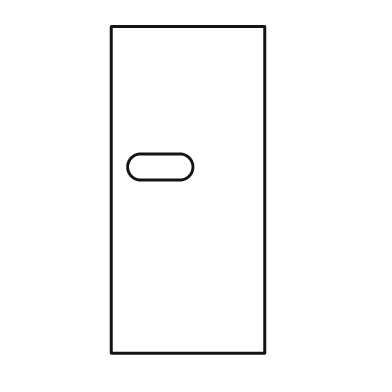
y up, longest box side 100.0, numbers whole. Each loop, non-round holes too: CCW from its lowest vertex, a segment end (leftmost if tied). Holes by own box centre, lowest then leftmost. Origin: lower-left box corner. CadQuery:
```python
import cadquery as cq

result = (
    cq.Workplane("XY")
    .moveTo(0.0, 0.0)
    .lineTo(47.0, 0.0)
    .lineTo(47.0, 100.0)
    .lineTo(0.0, 100.0)
    .close()
    .moveTo(9.0, 53.0)
    .lineTo(21.0, 53.0)
    .threePointArc((25.0, 57.0), (21.0, 61.0))
    .lineTo(9.0, 61.0)
    .threePointArc((5.0, 57.0), (9.0, 53.0))
    .close()
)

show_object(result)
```